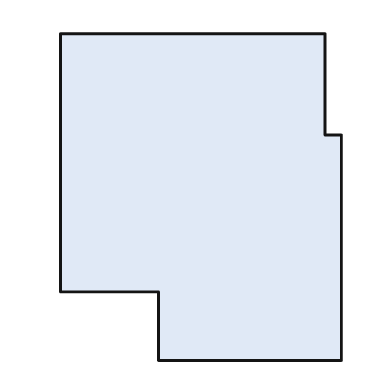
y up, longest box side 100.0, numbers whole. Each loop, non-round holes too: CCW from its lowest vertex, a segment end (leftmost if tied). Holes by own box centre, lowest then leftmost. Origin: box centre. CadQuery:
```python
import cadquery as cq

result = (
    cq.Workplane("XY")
    .moveTo(-13.0, -50.0)
    .lineTo(43.0, -50.0)
    .lineTo(43.0, 19.0)
    .lineTo(38.0, 19.0)
    .lineTo(38.0, 50.0)
    .lineTo(-43.0, 50.0)
    .lineTo(-43.0, -29.0)
    .lineTo(-13.0, -29.0)
    .close()
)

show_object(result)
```